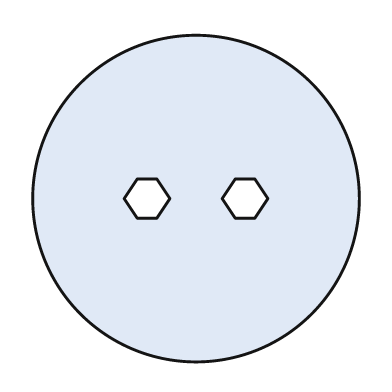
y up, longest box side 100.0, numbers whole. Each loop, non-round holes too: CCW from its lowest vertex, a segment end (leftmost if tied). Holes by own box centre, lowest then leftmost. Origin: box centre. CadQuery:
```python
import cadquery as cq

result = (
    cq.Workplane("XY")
    .moveTo(0.0, 0.0)
    .circle(50.0)
    .moveTo(-18.0, -6.0)
    .lineTo(-12.0, -6.0)
    .lineTo(-8.0, 0.0)
    .lineTo(-12.0, 6.0)
    .lineTo(-18.0, 6.0)
    .lineTo(-22.0, 0.0)
    .close()
    .moveTo(12.0, -6.0)
    .lineTo(18.0, -6.0)
    .lineTo(22.0, 0.0)
    .lineTo(18.0, 6.0)
    .lineTo(12.0, 6.0)
    .lineTo(8.0, 0.0)
    .close()
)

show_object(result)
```